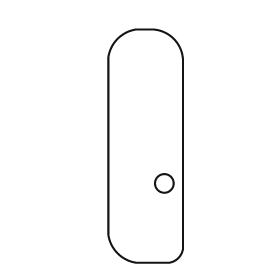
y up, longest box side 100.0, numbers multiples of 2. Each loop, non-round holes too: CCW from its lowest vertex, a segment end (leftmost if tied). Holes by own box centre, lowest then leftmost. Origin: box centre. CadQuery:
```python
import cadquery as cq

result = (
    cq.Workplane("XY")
    .moveTo(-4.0, -50.0)
    .lineTo(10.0, -50.0)
    .threePointArc((14.0, -48.0), (16.0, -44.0))
    .lineTo(16.0, 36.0)
    .threePointArc((12.0, 46.0), (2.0, 50.0))
    .lineTo(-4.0, 50.0)
    .threePointArc((-12.0, 46.0), (-16.0, 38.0))
    .lineTo(-16.0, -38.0)
    .threePointArc((-12.0, -46.0), (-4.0, -50.0))
    .close()
    .moveTo(8.0, -16.0)
    .circle(4.0)
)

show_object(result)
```